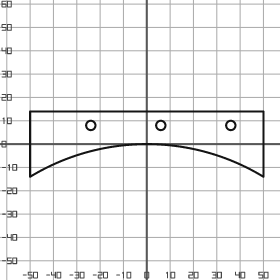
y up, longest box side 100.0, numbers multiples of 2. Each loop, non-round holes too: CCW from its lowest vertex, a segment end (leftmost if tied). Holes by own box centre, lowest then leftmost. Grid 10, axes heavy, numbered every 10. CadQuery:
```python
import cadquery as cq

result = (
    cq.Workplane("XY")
    .moveTo(-50.0, -14.0)
    .threePointArc((0.0, 0.0), (50.0, -14.0))
    .lineTo(50.0, 14.0)
    .lineTo(-50.0, 14.0)
    .close()
    .moveTo(-24.0, 8.0)
    .circle(2.0)
    .moveTo(6.0, 8.0)
    .circle(2.0)
    .moveTo(36.0, 8.0)
    .circle(2.0)
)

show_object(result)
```